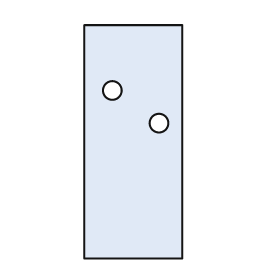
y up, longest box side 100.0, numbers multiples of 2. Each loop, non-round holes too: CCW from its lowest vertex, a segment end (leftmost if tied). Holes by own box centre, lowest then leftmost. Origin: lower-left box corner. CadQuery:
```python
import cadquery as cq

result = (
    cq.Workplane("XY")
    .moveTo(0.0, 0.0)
    .lineTo(42.0, 0.0)
    .lineTo(42.0, 100.0)
    .lineTo(0.0, 100.0)
    .close()
    .moveTo(32.0, 58.0)
    .circle(4.0)
    .moveTo(12.0, 72.0)
    .circle(4.0)
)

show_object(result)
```